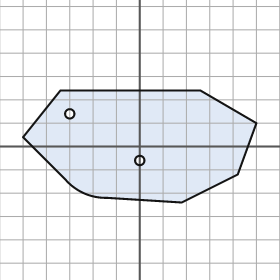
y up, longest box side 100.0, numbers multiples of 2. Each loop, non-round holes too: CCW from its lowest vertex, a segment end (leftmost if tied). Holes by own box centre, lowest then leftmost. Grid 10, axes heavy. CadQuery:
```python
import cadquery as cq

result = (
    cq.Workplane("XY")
    .moveTo(18.0, -24.0)
    .lineTo(42.0, -12.0)
    .lineTo(50.0, 10.0)
    .lineTo(26.0, 24.0)
    .lineTo(-34.0, 24.0)
    .lineTo(-50.0, 4.0)
    .lineTo(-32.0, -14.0)
    .threePointArc((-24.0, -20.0), (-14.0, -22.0))
    .close()
    .moveTo(0.0, -6.0)
    .circle(2.0)
    .moveTo(-30.0, 14.0)
    .circle(2.0)
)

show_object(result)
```